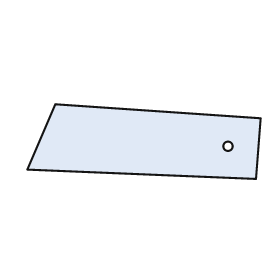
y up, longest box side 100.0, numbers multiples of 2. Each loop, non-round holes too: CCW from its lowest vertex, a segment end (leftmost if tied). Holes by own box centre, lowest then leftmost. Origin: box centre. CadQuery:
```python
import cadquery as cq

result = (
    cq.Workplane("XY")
    .moveTo(48.0, -16.0)
    .lineTo(50.0, 10.0)
    .lineTo(-38.0, 16.0)
    .lineTo(-50.0, -12.0)
    .close()
    .moveTo(36.0, -2.0)
    .circle(2.0)
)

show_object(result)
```